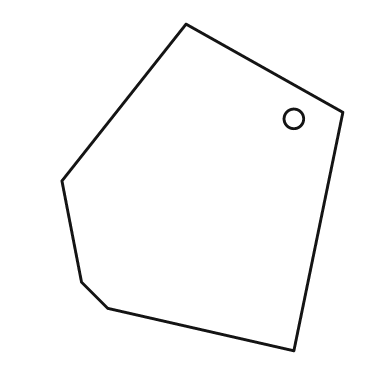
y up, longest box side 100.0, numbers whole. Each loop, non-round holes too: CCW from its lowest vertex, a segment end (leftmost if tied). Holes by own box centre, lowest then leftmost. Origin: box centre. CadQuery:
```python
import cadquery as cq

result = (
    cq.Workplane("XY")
    .moveTo(28.0, -50.0)
    .lineTo(43.0, 23.0)
    .lineTo(-5.0, 50.0)
    .lineTo(-43.0, 2.0)
    .lineTo(-37.0, -29.0)
    .lineTo(-29.0, -37.0)
    .close()
    .moveTo(28.0, 21.0)
    .circle(3.0)
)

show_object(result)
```